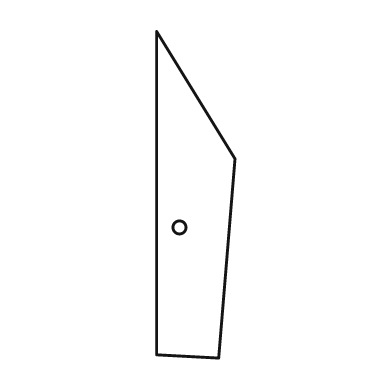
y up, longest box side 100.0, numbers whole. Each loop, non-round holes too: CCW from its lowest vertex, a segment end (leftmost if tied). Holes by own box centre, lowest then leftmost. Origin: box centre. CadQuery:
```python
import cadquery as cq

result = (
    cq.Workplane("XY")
    .moveTo(7.0, -50.0)
    .lineTo(12.0, 11.0)
    .lineTo(-12.0, 50.0)
    .lineTo(-12.0, -49.0)
    .close()
    .moveTo(-5.0, -10.0)
    .circle(2.0)
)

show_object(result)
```